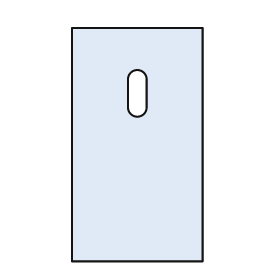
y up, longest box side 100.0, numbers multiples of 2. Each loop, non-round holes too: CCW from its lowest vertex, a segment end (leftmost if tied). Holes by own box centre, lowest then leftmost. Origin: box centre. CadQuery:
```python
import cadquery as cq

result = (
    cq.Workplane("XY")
    .moveTo(-28.0, -50.0)
    .lineTo(28.0, -50.0)
    .lineTo(28.0, 50.0)
    .lineTo(-28.0, 50.0)
    .close()
    .moveTo(-4.0, 16.0)
    .threePointArc((0.0, 12.0), (4.0, 16.0))
    .lineTo(4.0, 28.0)
    .threePointArc((0.0, 32.0), (-4.0, 28.0))
    .close()
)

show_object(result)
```